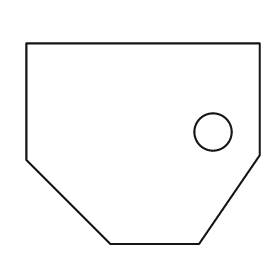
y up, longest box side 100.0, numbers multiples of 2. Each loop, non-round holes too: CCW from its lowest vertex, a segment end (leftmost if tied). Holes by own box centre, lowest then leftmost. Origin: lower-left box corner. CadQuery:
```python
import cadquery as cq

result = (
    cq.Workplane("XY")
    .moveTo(36.0, 0.0)
    .lineTo(74.0, 0.0)
    .lineTo(100.0, 38.0)
    .lineTo(100.0, 86.0)
    .lineTo(0.0, 86.0)
    .lineTo(0.0, 36.0)
    .close()
    .moveTo(80.0, 48.0)
    .circle(8.0)
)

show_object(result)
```